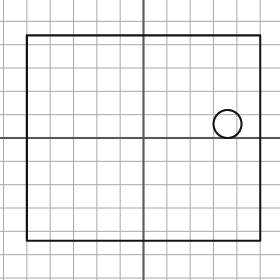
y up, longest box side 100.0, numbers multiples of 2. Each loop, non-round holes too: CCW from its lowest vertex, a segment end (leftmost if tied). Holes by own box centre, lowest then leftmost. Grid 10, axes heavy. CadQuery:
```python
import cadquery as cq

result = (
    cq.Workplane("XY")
    .moveTo(-50.0, -44.0)
    .lineTo(50.0, -44.0)
    .lineTo(50.0, 44.0)
    .lineTo(-50.0, 44.0)
    .close()
    .moveTo(36.0, 6.0)
    .circle(6.0)
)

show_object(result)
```